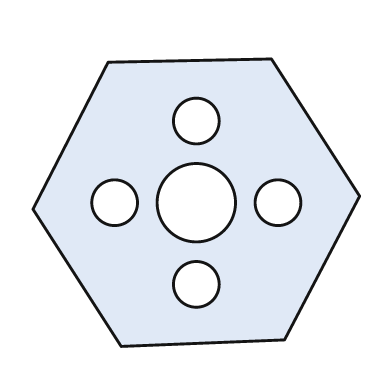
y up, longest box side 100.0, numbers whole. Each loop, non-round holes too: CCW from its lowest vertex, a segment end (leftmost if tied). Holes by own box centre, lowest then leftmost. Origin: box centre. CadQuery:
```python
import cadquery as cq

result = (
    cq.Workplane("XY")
    .moveTo(-23.0, -44.0)
    .lineTo(27.0, -42.0)
    .lineTo(50.0, 2.0)
    .lineTo(23.0, 44.0)
    .lineTo(-27.0, 43.0)
    .lineTo(-50.0, -2.0)
    .close()
    .moveTo(0.0, -25.0)
    .circle(7.0)
    .moveTo(-25.0, 0.0)
    .circle(7.0)
    .moveTo(0.0, 0.0)
    .circle(12.0)
    .moveTo(25.0, 0.0)
    .circle(7.0)
    .moveTo(0.0, 25.0)
    .circle(7.0)
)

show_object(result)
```